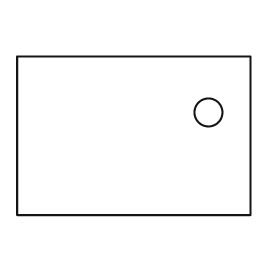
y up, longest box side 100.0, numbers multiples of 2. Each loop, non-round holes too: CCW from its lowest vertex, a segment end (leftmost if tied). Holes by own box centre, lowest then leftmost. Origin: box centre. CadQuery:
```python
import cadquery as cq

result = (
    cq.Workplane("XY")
    .moveTo(-50.0, -34.0)
    .lineTo(50.0, -34.0)
    .lineTo(50.0, 34.0)
    .lineTo(-50.0, 34.0)
    .close()
    .moveTo(32.0, 10.0)
    .circle(6.0)
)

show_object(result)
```